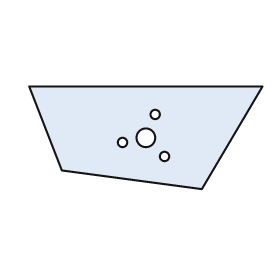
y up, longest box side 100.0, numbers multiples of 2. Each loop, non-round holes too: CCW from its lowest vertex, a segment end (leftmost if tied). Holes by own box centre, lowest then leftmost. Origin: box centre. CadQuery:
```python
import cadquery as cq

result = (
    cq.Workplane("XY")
    .moveTo(24.0, -22.0)
    .lineTo(50.0, 22.0)
    .lineTo(-50.0, 22.0)
    .lineTo(-36.0, -14.0)
    .close()
    .moveTo(8.0, -8.0)
    .circle(2.0)
    .moveTo(-10.0, -2.0)
    .circle(2.0)
    .moveTo(0.0, 0.0)
    .circle(4.0)
    .moveTo(4.0, 10.0)
    .circle(2.0)
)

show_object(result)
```